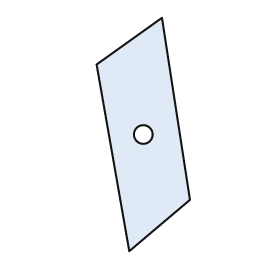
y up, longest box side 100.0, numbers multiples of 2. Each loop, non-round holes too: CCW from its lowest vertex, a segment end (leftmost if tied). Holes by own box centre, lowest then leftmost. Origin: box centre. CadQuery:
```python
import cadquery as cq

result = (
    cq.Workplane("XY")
    .moveTo(-6.0, -50.0)
    .lineTo(20.0, -28.0)
    .lineTo(8.0, 50.0)
    .lineTo(-20.0, 30.0)
    .close()
    .moveTo(0.0, 0.0)
    .circle(4.0)
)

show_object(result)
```